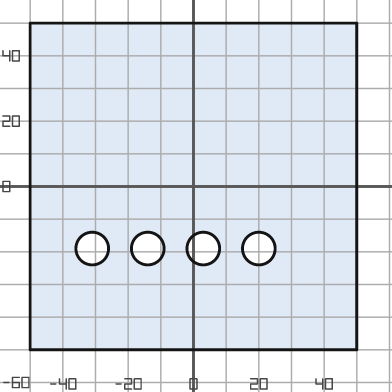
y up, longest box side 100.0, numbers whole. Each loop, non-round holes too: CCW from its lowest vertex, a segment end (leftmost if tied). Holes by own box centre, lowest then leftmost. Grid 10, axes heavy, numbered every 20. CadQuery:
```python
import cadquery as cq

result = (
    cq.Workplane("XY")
    .moveTo(-50.0, -50.0)
    .lineTo(50.0, -50.0)
    .lineTo(50.0, 50.0)
    .lineTo(-50.0, 50.0)
    .close()
    .moveTo(-31.0, -19.0)
    .circle(5.0)
    .moveTo(-14.0, -19.0)
    .circle(5.0)
    .moveTo(3.0, -19.0)
    .circle(5.0)
    .moveTo(20.0, -19.0)
    .circle(5.0)
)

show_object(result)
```